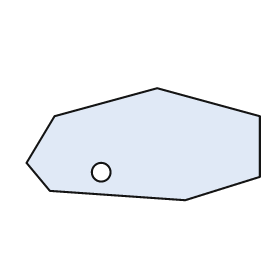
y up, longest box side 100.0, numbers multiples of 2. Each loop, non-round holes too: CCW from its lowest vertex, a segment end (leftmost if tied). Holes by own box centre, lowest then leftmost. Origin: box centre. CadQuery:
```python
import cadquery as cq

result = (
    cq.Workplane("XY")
    .moveTo(18.0, -24.0)
    .lineTo(50.0, -14.0)
    .lineTo(50.0, 12.0)
    .lineTo(6.0, 24.0)
    .lineTo(-38.0, 12.0)
    .lineTo(-50.0, -8.0)
    .lineTo(-40.0, -20.0)
    .close()
    .moveTo(-18.0, -12.0)
    .circle(4.0)
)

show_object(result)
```